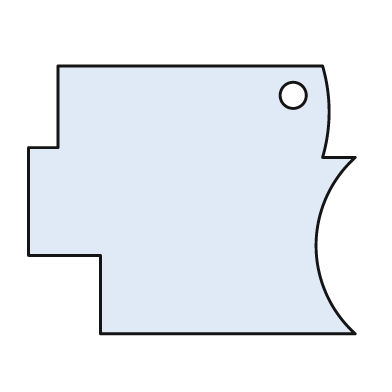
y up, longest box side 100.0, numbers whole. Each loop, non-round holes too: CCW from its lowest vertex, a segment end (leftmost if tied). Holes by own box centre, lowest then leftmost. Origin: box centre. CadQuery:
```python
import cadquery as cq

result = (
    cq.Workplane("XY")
    .moveTo(-28.0, -41.0)
    .lineTo(50.0, -41.0)
    .threePointArc((38.0, -14.0), (50.0, 13.0))
    .lineTo(40.0, 13.0)
    .threePointArc((42.0, 27.0), (40.0, 41.0))
    .lineTo(-41.0, 41.0)
    .lineTo(-41.0, 16.0)
    .lineTo(-50.0, 16.0)
    .lineTo(-50.0, -17.0)
    .lineTo(-28.0, -17.0)
    .close()
    .moveTo(31.0, 32.0)
    .circle(4.0)
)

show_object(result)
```